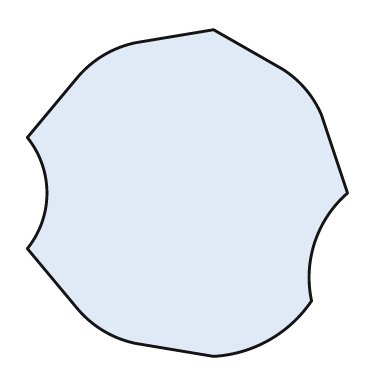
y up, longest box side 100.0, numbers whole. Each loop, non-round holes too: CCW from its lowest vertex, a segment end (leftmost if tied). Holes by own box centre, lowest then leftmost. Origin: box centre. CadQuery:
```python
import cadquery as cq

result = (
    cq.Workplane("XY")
    .moveTo(8.0, -50.0)
    .threePointArc((25.0, -45.0), (38.0, -33.0))
    .threePointArc((39.0, -15.0), (49.0, 0.0))
    .lineTo(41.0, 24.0)
    .threePointArc((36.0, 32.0), (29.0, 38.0))
    .lineTo(8.0, 50.0)
    .lineTo(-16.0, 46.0)
    .threePointArc((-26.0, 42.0), (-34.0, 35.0))
    .lineTo(-49.0, 17.0)
    .threePointArc((-43.0, 0.0), (-49.0, -17.0))
    .lineTo(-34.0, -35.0)
    .threePointArc((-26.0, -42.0), (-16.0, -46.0))
    .close()
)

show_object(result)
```